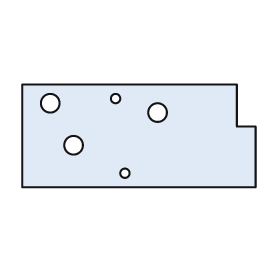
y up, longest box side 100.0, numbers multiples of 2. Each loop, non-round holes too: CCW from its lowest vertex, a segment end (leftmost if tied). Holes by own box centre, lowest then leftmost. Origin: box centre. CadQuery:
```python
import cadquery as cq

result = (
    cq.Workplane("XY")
    .moveTo(-50.0, -22.0)
    .lineTo(50.0, -22.0)
    .lineTo(50.0, 4.0)
    .lineTo(42.0, 4.0)
    .lineTo(42.0, 22.0)
    .lineTo(-50.0, 22.0)
    .close()
    .moveTo(-6.0, -16.0)
    .circle(2.0)
    .moveTo(-28.0, -4.0)
    .circle(4.0)
    .moveTo(8.0, 10.0)
    .circle(4.0)
    .moveTo(-38.0, 14.0)
    .circle(4.0)
    .moveTo(-10.0, 16.0)
    .circle(2.0)
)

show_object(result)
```